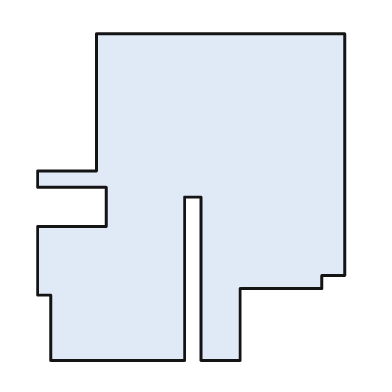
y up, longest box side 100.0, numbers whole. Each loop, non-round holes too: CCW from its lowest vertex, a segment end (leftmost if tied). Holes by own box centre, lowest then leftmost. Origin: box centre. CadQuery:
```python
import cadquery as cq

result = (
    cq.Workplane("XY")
    .moveTo(-43.0, -50.0)
    .lineTo(-2.0, -50.0)
    .lineTo(-2.0, 0.0)
    .lineTo(3.0, 0.0)
    .lineTo(3.0, -50.0)
    .lineTo(15.0, -50.0)
    .lineTo(15.0, -28.0)
    .lineTo(40.0, -28.0)
    .lineTo(40.0, -24.0)
    .lineTo(47.0, -24.0)
    .lineTo(47.0, 50.0)
    .lineTo(-29.0, 50.0)
    .lineTo(-29.0, 8.0)
    .lineTo(-47.0, 8.0)
    .lineTo(-47.0, 3.0)
    .lineTo(-26.0, 3.0)
    .lineTo(-26.0, -9.0)
    .lineTo(-47.0, -9.0)
    .lineTo(-47.0, -30.0)
    .lineTo(-43.0, -30.0)
    .close()
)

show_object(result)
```